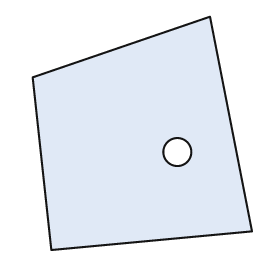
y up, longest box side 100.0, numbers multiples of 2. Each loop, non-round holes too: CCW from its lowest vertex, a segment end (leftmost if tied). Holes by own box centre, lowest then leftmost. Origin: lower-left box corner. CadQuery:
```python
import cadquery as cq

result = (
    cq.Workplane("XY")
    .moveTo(8.0, 0.0)
    .lineTo(94.0, 8.0)
    .lineTo(76.0, 100.0)
    .lineTo(0.0, 74.0)
    .close()
    .moveTo(62.0, 42.0)
    .circle(6.0)
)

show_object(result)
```